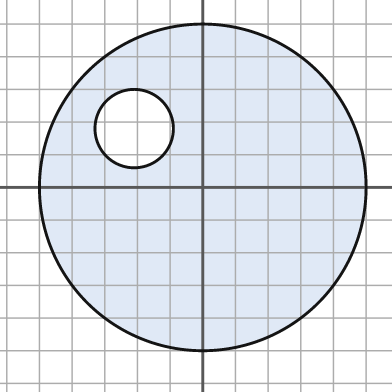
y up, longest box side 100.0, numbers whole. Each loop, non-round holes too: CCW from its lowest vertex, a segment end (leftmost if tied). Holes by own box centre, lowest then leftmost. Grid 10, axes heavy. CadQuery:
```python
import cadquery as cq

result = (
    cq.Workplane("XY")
    .moveTo(0.0, 0.0)
    .circle(50.0)
    .moveTo(-21.0, 18.0)
    .circle(12.0)
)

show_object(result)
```